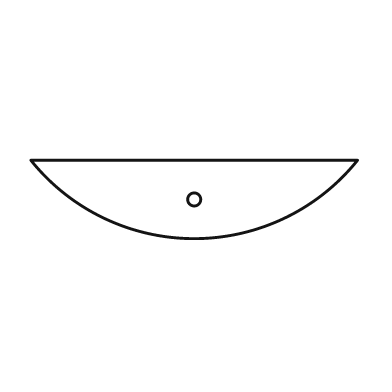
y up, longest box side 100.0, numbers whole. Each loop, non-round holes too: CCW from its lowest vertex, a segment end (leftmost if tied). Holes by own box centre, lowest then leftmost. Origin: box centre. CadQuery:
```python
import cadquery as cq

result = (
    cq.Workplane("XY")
    .moveTo(-50.0, 12.0)
    .threePointArc((0.0, -12.0), (50.0, 12.0))
    .close()
    .moveTo(0.0, 0.0)
    .circle(2.0)
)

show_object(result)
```